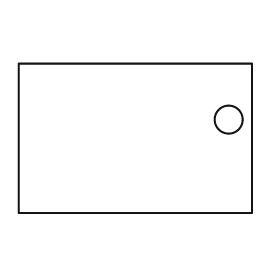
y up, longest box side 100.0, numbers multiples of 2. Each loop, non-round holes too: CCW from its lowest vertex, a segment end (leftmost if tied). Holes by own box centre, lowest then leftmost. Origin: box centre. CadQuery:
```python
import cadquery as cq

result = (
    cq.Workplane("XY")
    .moveTo(-50.0, -32.0)
    .lineTo(50.0, -32.0)
    .lineTo(50.0, 32.0)
    .lineTo(-50.0, 32.0)
    .close()
    .moveTo(40.0, 8.0)
    .circle(6.0)
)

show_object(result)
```